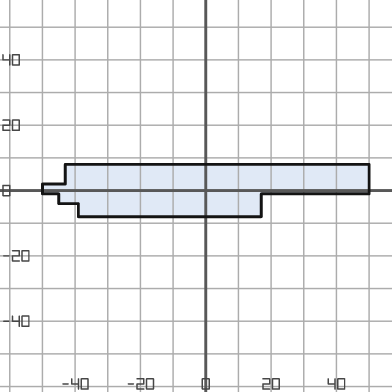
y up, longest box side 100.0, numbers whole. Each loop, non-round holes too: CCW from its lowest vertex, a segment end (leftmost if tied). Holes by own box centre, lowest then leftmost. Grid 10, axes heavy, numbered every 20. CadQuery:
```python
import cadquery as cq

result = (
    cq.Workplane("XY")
    .moveTo(-39.0, -8.0)
    .lineTo(17.0, -8.0)
    .lineTo(17.0, -1.0)
    .lineTo(50.0, -1.0)
    .lineTo(50.0, 8.0)
    .lineTo(-43.0, 8.0)
    .lineTo(-43.0, 2.0)
    .lineTo(-50.0, 2.0)
    .lineTo(-50.0, -1.0)
    .lineTo(-45.0, -1.0)
    .lineTo(-45.0, -4.0)
    .lineTo(-39.0, -4.0)
    .close()
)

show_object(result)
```